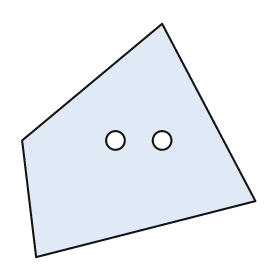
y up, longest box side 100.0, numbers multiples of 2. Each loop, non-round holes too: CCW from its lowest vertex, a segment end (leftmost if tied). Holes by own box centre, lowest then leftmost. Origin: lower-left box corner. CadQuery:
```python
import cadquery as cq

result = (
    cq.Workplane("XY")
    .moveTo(6.0, 0.0)
    .lineTo(100.0, 24.0)
    .lineTo(60.0, 100.0)
    .lineTo(0.0, 50.0)
    .close()
    .moveTo(40.0, 50.0)
    .circle(4.0)
    .moveTo(60.0, 50.0)
    .circle(4.0)
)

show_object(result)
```